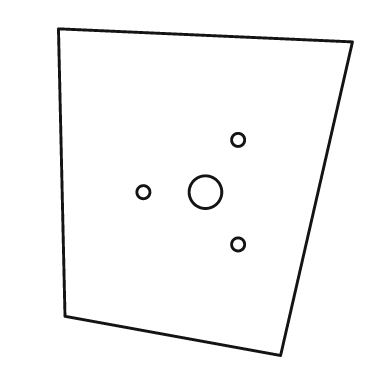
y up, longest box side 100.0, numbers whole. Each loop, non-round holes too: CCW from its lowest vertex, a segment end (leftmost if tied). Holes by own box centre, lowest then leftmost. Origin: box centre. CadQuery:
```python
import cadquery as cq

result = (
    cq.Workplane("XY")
    .moveTo(23.0, -50.0)
    .lineTo(45.0, 46.0)
    .lineTo(-45.0, 50.0)
    .lineTo(-43.0, -38.0)
    .close()
    .moveTo(10.0, -16.0)
    .circle(2.0)
    .moveTo(-19.0, 0.0)
    .circle(2.0)
    .moveTo(0.0, 0.0)
    .circle(5.0)
    .moveTo(10.0, 16.0)
    .circle(2.0)
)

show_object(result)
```